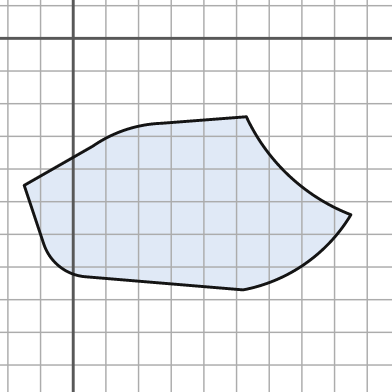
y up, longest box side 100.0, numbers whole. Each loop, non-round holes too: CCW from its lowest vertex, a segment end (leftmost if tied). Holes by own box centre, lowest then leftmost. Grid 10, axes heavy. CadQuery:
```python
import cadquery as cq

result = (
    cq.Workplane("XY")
    .moveTo(52.0, -77.0)
    .threePointArc((71.0, -69.0), (85.0, -54.0))
    .threePointArc((66.0, -42.0), (53.0, -24.0))
    .lineTo(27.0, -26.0)
    .threePointArc((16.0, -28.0), (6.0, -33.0))
    .lineTo(-15.0, -45.0)
    .lineTo(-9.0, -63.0)
    .threePointArc((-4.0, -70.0), (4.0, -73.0))
    .close()
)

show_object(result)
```